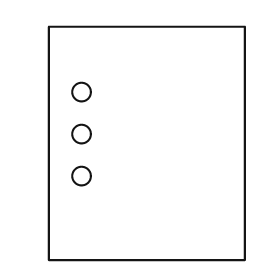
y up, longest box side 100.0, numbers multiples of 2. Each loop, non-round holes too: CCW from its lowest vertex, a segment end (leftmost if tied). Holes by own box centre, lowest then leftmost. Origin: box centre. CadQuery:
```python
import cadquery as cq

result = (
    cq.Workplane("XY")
    .moveTo(-42.0, -50.0)
    .lineTo(42.0, -50.0)
    .lineTo(42.0, 50.0)
    .lineTo(-42.0, 50.0)
    .close()
    .moveTo(-28.0, -14.0)
    .circle(4.0)
    .moveTo(-28.0, 4.0)
    .circle(4.0)
    .moveTo(-28.0, 22.0)
    .circle(4.0)
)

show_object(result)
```